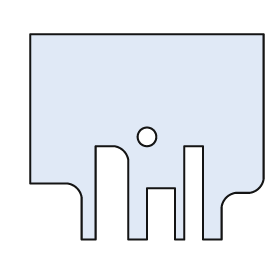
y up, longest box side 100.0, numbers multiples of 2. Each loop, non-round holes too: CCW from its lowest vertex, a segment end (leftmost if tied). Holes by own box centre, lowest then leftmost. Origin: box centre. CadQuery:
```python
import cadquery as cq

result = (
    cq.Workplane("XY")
    .moveTo(-28.0, -44.0)
    .lineTo(-22.0, -44.0)
    .lineTo(-22.0, -4.0)
    .lineTo(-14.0, -4.0)
    .threePointArc((-10.0, -6.0), (-8.0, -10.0))
    .lineTo(-8.0, -44.0)
    .lineTo(0.0, -44.0)
    .lineTo(0.0, -22.0)
    .lineTo(12.0, -22.0)
    .lineTo(12.0, -44.0)
    .lineTo(16.0, -44.0)
    .lineTo(16.0, -4.0)
    .lineTo(24.0, -4.0)
    .lineTo(24.0, -44.0)
    .lineTo(32.0, -44.0)
    .lineTo(32.0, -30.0)
    .threePointArc((34.0, -26.0), (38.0, -24.0))
    .lineTo(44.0, -24.0)
    .threePointArc((48.0, -22.0), (50.0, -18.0))
    .lineTo(50.0, 44.0)
    .lineTo(-50.0, 44.0)
    .lineTo(-50.0, -20.0)
    .lineTo(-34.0, -20.0)
    .threePointArc((-30.0, -22.0), (-28.0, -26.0))
    .close()
    .moveTo(0.0, 0.0)
    .circle(4.0)
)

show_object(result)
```